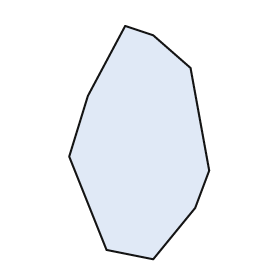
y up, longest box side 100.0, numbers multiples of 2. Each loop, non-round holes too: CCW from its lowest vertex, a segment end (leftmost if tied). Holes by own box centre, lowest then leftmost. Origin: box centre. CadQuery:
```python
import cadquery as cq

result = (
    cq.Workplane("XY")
    .moveTo(6.0, -50.0)
    .lineTo(24.0, -28.0)
    .lineTo(30.0, -12.0)
    .lineTo(22.0, 32.0)
    .lineTo(6.0, 46.0)
    .lineTo(-6.0, 50.0)
    .lineTo(-22.0, 20.0)
    .lineTo(-30.0, -6.0)
    .lineTo(-14.0, -46.0)
    .close()
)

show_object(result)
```